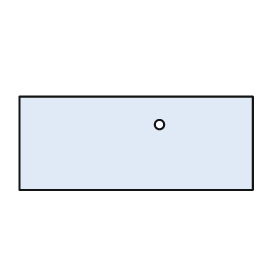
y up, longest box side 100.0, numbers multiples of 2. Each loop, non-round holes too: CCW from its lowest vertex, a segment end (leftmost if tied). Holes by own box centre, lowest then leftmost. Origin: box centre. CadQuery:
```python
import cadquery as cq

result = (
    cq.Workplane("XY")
    .moveTo(-50.0, -20.0)
    .lineTo(50.0, -20.0)
    .lineTo(50.0, 20.0)
    .lineTo(-50.0, 20.0)
    .close()
    .moveTo(10.0, 8.0)
    .circle(2.0)
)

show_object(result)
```